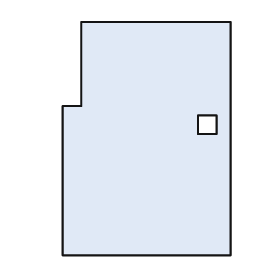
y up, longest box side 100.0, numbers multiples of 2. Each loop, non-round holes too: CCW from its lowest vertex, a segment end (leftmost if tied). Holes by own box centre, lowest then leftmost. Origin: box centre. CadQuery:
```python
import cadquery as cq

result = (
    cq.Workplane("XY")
    .moveTo(-36.0, -50.0)
    .lineTo(36.0, -50.0)
    .lineTo(36.0, 50.0)
    .lineTo(-28.0, 50.0)
    .lineTo(-28.0, 14.0)
    .lineTo(-36.0, 14.0)
    .close()
    .moveTo(22.0, 2.0)
    .lineTo(30.0, 2.0)
    .lineTo(30.0, 10.0)
    .lineTo(22.0, 10.0)
    .close()
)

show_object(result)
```